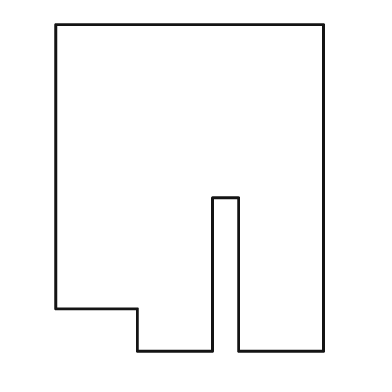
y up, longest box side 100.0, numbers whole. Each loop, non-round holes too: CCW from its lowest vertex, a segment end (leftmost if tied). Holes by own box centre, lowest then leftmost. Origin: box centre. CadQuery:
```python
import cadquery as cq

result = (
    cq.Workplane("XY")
    .moveTo(-16.0, -50.0)
    .lineTo(7.0, -50.0)
    .lineTo(7.0, -3.0)
    .lineTo(15.0, -3.0)
    .lineTo(15.0, -50.0)
    .lineTo(41.0, -50.0)
    .lineTo(41.0, 50.0)
    .lineTo(-41.0, 50.0)
    .lineTo(-41.0, -37.0)
    .lineTo(-16.0, -37.0)
    .close()
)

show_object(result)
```